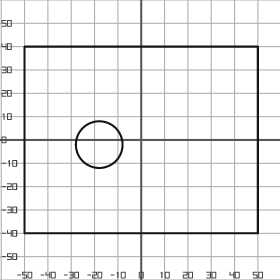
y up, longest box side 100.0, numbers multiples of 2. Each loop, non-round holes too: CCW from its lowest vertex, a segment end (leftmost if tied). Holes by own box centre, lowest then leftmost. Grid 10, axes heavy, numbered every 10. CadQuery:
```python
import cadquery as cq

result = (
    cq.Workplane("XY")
    .moveTo(-50.0, -40.0)
    .lineTo(50.0, -40.0)
    .lineTo(50.0, 40.0)
    .lineTo(-50.0, 40.0)
    .close()
    .moveTo(-18.0, -2.0)
    .circle(10.0)
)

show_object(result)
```